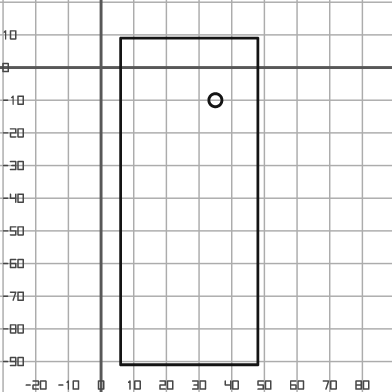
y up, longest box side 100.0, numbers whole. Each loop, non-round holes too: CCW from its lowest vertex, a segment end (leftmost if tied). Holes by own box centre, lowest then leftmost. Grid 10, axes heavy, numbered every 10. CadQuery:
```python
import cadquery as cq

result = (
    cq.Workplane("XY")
    .moveTo(6.0, -91.0)
    .lineTo(48.0, -91.0)
    .lineTo(48.0, 9.0)
    .lineTo(6.0, 9.0)
    .close()
    .moveTo(35.0, -10.0)
    .circle(2.0)
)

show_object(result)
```